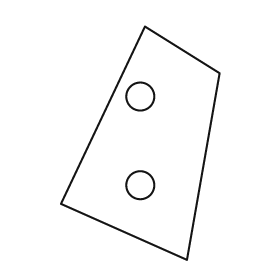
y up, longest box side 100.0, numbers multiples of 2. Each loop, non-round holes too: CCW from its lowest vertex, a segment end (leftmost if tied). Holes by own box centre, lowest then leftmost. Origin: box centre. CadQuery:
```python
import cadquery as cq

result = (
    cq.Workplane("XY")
    .moveTo(20.0, -50.0)
    .lineTo(34.0, 30.0)
    .lineTo(2.0, 50.0)
    .lineTo(-34.0, -26.0)
    .close()
    .moveTo(0.0, -18.0)
    .circle(6.0)
    .moveTo(0.0, 20.0)
    .circle(6.0)
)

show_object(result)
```